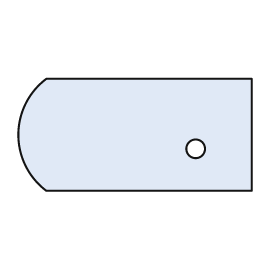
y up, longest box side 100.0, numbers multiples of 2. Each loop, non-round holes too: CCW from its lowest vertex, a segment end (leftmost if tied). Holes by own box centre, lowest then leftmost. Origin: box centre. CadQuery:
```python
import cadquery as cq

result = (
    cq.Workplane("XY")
    .moveTo(-38.0, -24.0)
    .lineTo(50.0, -24.0)
    .lineTo(50.0, 24.0)
    .lineTo(-38.0, 24.0)
    .threePointArc((-50.0, 0.0), (-38.0, -24.0))
    .close()
    .moveTo(26.0, -6.0)
    .circle(4.0)
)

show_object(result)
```